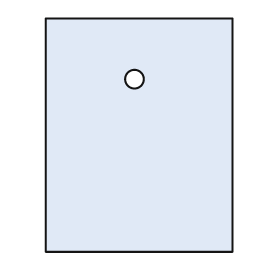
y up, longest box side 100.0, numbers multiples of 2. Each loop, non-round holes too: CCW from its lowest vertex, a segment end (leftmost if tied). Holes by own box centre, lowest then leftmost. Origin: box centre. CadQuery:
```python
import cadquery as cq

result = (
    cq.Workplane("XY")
    .moveTo(-40.0, -50.0)
    .lineTo(40.0, -50.0)
    .lineTo(40.0, 50.0)
    .lineTo(-40.0, 50.0)
    .close()
    .moveTo(-2.0, 24.0)
    .circle(4.0)
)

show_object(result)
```